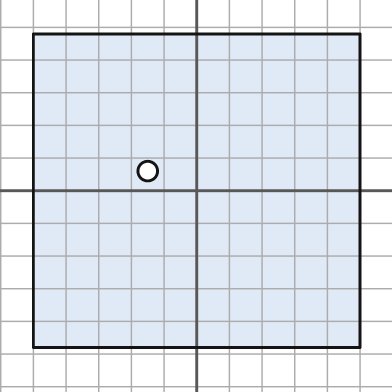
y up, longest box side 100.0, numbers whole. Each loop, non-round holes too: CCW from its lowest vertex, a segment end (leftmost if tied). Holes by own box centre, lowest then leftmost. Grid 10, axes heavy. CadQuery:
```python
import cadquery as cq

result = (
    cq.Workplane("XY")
    .moveTo(-50.0, -48.0)
    .lineTo(50.0, -48.0)
    .lineTo(50.0, 48.0)
    .lineTo(-50.0, 48.0)
    .close()
    .moveTo(-15.0, 6.0)
    .circle(3.0)
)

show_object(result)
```